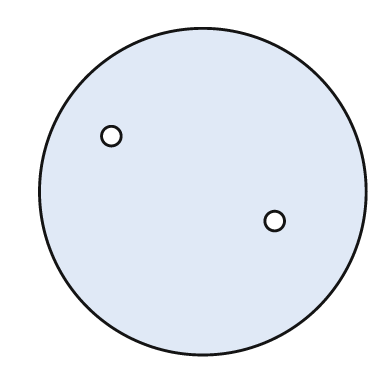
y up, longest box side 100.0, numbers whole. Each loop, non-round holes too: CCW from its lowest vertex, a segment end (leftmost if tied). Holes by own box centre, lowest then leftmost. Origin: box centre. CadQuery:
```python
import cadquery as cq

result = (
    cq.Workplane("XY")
    .moveTo(0.0, 0.0)
    .circle(50.0)
    .moveTo(22.0, -9.0)
    .circle(3.0)
    .moveTo(-28.0, 17.0)
    .circle(3.0)
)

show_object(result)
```